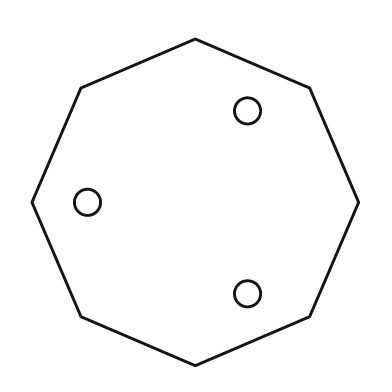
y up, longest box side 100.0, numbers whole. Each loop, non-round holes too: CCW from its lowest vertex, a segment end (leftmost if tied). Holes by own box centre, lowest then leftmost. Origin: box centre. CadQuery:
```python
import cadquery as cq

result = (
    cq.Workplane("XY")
    .moveTo(0.0, -50.0)
    .lineTo(35.0, -35.0)
    .lineTo(50.0, 0.0)
    .lineTo(35.0, 35.0)
    .lineTo(0.0, 50.0)
    .lineTo(-35.0, 35.0)
    .lineTo(-50.0, 0.0)
    .lineTo(-35.0, -35.0)
    .close()
    .moveTo(16.0, -28.0)
    .circle(4.0)
    .moveTo(-33.0, 0.0)
    .circle(4.0)
    .moveTo(16.0, 28.0)
    .circle(4.0)
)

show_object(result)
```